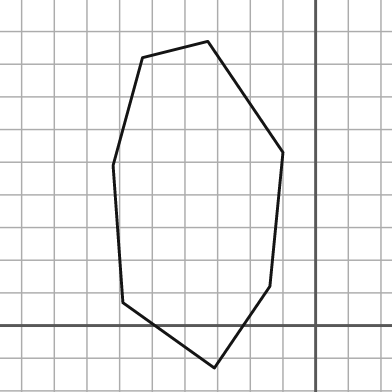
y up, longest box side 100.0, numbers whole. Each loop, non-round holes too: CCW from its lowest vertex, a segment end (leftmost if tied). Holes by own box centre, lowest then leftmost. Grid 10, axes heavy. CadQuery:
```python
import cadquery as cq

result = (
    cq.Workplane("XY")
    .moveTo(-31.0, -13.0)
    .lineTo(-14.0, 12.0)
    .lineTo(-10.0, 53.0)
    .lineTo(-33.0, 87.0)
    .lineTo(-53.0, 82.0)
    .lineTo(-62.0, 49.0)
    .lineTo(-59.0, 7.0)
    .close()
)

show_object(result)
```